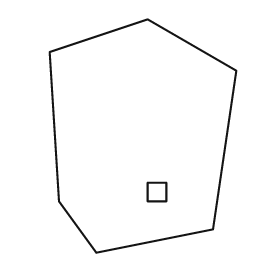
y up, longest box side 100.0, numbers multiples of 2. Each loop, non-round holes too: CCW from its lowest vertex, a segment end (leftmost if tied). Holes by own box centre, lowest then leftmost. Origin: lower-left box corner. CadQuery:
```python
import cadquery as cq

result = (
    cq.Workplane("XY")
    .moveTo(20.0, 0.0)
    .lineTo(70.0, 10.0)
    .lineTo(80.0, 78.0)
    .lineTo(42.0, 100.0)
    .lineTo(0.0, 86.0)
    .lineTo(4.0, 22.0)
    .close()
    .moveTo(42.0, 22.0)
    .lineTo(50.0, 22.0)
    .lineTo(50.0, 30.0)
    .lineTo(42.0, 30.0)
    .close()
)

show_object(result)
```